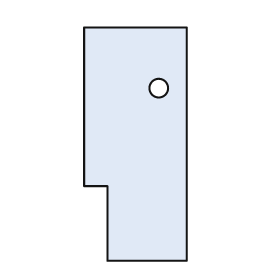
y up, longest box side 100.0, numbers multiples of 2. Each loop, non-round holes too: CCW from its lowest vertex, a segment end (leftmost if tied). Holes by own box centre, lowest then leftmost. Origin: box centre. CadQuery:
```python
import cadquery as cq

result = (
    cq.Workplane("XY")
    .moveTo(-12.0, -50.0)
    .lineTo(22.0, -50.0)
    .lineTo(22.0, 50.0)
    .lineTo(-22.0, 50.0)
    .lineTo(-22.0, -18.0)
    .lineTo(-12.0, -18.0)
    .close()
    .moveTo(10.0, 24.0)
    .circle(4.0)
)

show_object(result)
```